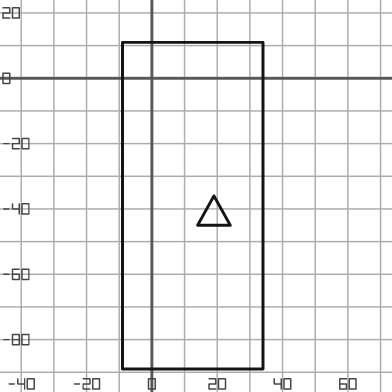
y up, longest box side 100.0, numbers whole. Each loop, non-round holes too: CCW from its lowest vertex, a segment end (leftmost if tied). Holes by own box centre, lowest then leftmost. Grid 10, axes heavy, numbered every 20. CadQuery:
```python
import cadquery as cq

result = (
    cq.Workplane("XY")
    .moveTo(-9.0, -89.0)
    .lineTo(34.0, -89.0)
    .lineTo(34.0, 11.0)
    .lineTo(-9.0, 11.0)
    .close()
    .moveTo(14.0, -45.0)
    .lineTo(24.0, -45.0)
    .lineTo(19.0, -36.0)
    .close()
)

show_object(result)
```